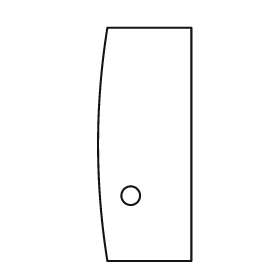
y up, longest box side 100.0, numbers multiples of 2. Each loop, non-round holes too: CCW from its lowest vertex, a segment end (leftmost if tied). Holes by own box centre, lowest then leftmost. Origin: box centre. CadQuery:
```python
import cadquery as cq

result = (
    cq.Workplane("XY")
    .moveTo(-16.0, -50.0)
    .lineTo(20.0, -50.0)
    .lineTo(20.0, 50.0)
    .lineTo(-16.0, 50.0)
    .threePointArc((-20.0, 0.0), (-16.0, -50.0))
    .close()
    .moveTo(-6.0, -22.0)
    .circle(4.0)
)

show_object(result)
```